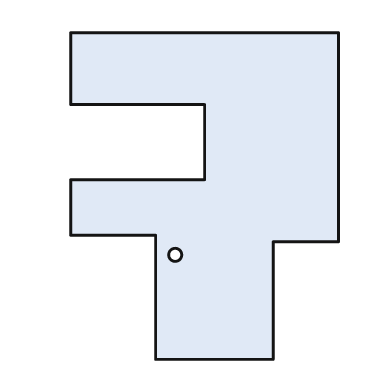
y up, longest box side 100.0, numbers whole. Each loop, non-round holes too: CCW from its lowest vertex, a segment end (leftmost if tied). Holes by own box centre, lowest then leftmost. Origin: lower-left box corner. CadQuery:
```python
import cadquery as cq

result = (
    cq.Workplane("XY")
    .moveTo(26.0, 0.0)
    .lineTo(62.0, 0.0)
    .lineTo(62.0, 36.0)
    .lineTo(82.0, 36.0)
    .lineTo(82.0, 100.0)
    .lineTo(0.0, 100.0)
    .lineTo(0.0, 78.0)
    .lineTo(41.0, 78.0)
    .lineTo(41.0, 55.0)
    .lineTo(0.0, 55.0)
    .lineTo(0.0, 38.0)
    .lineTo(26.0, 38.0)
    .close()
    .moveTo(32.0, 32.0)
    .circle(2.0)
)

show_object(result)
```